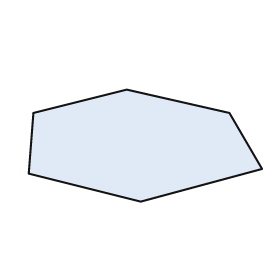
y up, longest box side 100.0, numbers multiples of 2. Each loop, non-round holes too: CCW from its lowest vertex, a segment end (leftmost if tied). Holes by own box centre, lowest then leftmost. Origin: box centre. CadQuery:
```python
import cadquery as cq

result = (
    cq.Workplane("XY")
    .moveTo(-2.0, -24.0)
    .lineTo(50.0, -10.0)
    .lineTo(36.0, 14.0)
    .lineTo(-8.0, 24.0)
    .lineTo(-48.0, 14.0)
    .lineTo(-50.0, -12.0)
    .close()
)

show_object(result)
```